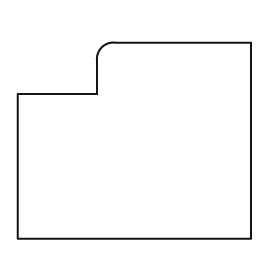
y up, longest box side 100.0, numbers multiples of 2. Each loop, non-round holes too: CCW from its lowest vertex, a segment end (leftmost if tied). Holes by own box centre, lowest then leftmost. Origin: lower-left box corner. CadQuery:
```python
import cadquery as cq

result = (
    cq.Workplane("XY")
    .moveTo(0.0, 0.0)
    .lineTo(100.0, 0.0)
    .lineTo(100.0, 84.0)
    .lineTo(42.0, 84.0)
    .threePointArc((36.0, 82.0), (34.0, 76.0))
    .lineTo(34.0, 62.0)
    .lineTo(0.0, 62.0)
    .close()
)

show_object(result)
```